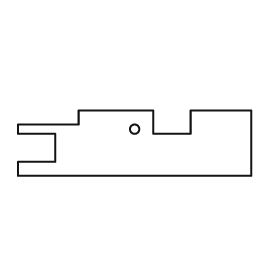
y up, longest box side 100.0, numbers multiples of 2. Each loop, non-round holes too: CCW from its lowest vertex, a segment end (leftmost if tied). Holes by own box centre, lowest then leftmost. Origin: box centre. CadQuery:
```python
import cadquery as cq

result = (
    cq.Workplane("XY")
    .moveTo(-50.0, -14.0)
    .lineTo(50.0, -14.0)
    .lineTo(50.0, 14.0)
    .lineTo(24.0, 14.0)
    .lineTo(24.0, 4.0)
    .lineTo(8.0, 4.0)
    .lineTo(8.0, 14.0)
    .lineTo(-24.0, 14.0)
    .lineTo(-24.0, 8.0)
    .lineTo(-50.0, 8.0)
    .lineTo(-50.0, 4.0)
    .lineTo(-34.0, 4.0)
    .lineTo(-34.0, -8.0)
    .lineTo(-50.0, -8.0)
    .close()
    .moveTo(0.0, 6.0)
    .circle(2.0)
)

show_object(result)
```